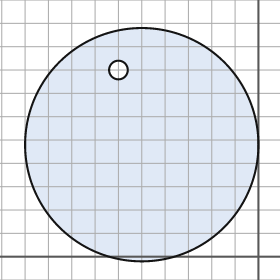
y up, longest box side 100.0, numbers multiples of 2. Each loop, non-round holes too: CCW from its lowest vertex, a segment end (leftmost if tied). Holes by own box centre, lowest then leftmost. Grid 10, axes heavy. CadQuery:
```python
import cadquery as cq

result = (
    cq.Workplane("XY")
    .moveTo(-50.0, 48.0)
    .circle(50.0)
    .moveTo(-60.0, 80.0)
    .circle(4.0)
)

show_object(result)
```